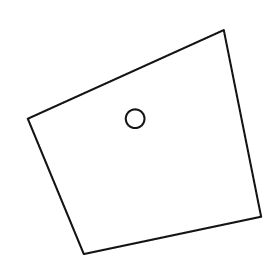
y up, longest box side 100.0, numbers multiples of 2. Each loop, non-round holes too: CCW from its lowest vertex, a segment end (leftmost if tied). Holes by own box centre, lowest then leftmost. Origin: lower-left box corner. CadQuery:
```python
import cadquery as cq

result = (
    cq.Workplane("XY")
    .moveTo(24.0, 0.0)
    .lineTo(100.0, 16.0)
    .lineTo(84.0, 96.0)
    .lineTo(0.0, 58.0)
    .close()
    .moveTo(46.0, 58.0)
    .circle(4.0)
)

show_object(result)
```